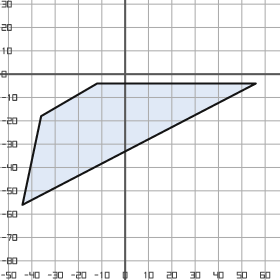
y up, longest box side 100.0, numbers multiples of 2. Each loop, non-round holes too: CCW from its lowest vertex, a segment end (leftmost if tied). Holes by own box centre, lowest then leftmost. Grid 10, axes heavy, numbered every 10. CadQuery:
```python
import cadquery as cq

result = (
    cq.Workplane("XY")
    .moveTo(-44.0, -56.0)
    .lineTo(56.0, -4.0)
    .lineTo(-12.0, -4.0)
    .lineTo(-36.0, -18.0)
    .close()
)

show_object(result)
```